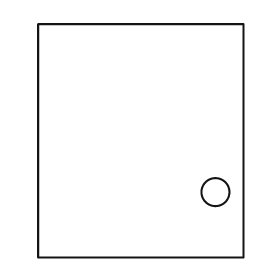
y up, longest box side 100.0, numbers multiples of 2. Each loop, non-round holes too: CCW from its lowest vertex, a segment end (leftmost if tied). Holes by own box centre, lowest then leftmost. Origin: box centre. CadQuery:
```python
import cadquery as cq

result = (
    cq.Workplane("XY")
    .moveTo(-44.0, -50.0)
    .lineTo(44.0, -50.0)
    .lineTo(44.0, 50.0)
    .lineTo(-44.0, 50.0)
    .close()
    .moveTo(32.0, -22.0)
    .circle(6.0)
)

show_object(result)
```